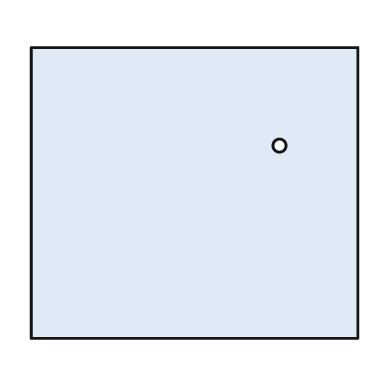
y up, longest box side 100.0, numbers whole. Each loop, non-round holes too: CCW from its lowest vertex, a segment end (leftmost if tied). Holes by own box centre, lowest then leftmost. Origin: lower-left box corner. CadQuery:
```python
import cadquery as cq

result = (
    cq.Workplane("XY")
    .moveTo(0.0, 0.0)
    .lineTo(100.0, 0.0)
    .lineTo(100.0, 89.0)
    .lineTo(0.0, 89.0)
    .close()
    .moveTo(76.0, 59.0)
    .circle(2.0)
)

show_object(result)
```